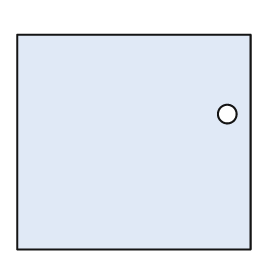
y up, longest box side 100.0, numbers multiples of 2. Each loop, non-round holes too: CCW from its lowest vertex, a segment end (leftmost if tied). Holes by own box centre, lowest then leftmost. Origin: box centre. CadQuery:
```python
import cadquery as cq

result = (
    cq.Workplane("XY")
    .moveTo(-50.0, -46.0)
    .lineTo(50.0, -46.0)
    .lineTo(50.0, 46.0)
    .lineTo(-50.0, 46.0)
    .close()
    .moveTo(40.0, 12.0)
    .circle(4.0)
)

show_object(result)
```